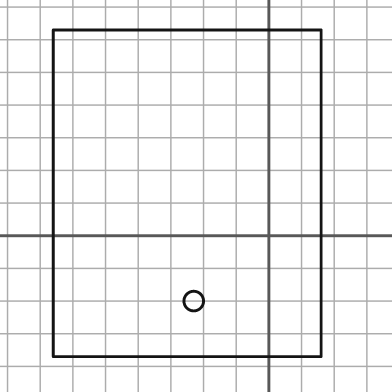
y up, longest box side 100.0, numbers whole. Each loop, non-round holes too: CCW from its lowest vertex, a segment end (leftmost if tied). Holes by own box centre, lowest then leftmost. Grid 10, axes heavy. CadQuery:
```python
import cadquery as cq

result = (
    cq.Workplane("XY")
    .moveTo(-66.0, -37.0)
    .lineTo(16.0, -37.0)
    .lineTo(16.0, 63.0)
    .lineTo(-66.0, 63.0)
    .close()
    .moveTo(-23.0, -20.0)
    .circle(3.0)
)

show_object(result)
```